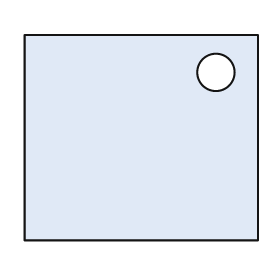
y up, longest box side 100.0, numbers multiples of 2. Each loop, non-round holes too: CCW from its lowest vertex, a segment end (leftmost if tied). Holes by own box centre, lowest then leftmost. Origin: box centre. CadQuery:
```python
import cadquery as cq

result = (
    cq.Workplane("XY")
    .moveTo(-50.0, -44.0)
    .lineTo(50.0, -44.0)
    .lineTo(50.0, 44.0)
    .lineTo(-50.0, 44.0)
    .close()
    .moveTo(32.0, 28.0)
    .circle(8.0)
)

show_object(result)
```